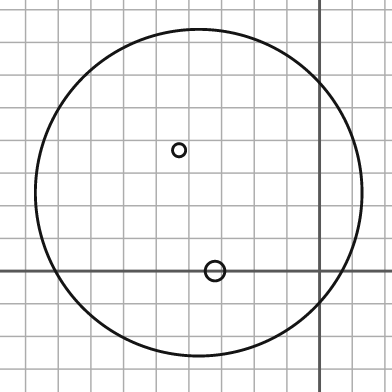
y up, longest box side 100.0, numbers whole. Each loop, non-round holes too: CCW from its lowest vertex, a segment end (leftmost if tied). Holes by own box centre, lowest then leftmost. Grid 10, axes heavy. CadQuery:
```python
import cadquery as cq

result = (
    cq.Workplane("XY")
    .moveTo(-37.0, 24.0)
    .circle(50.0)
    .moveTo(-32.0, 0.0)
    .circle(3.0)
    .moveTo(-43.0, 37.0)
    .circle(2.0)
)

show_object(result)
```